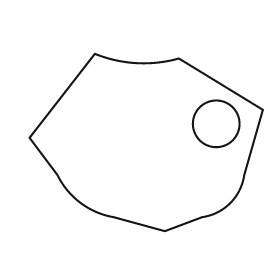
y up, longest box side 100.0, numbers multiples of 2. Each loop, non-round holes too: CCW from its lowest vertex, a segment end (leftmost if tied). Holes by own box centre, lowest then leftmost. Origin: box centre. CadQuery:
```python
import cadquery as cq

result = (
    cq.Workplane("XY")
    .moveTo(8.0, -38.0)
    .lineTo(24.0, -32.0)
    .threePointArc((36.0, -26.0), (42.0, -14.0))
    .lineTo(50.0, 14.0)
    .lineTo(14.0, 36.0)
    .threePointArc((-4.0, 34.0), (-22.0, 38.0))
    .lineTo(-50.0, 2.0)
    .lineTo(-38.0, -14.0)
    .threePointArc((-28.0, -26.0), (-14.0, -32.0))
    .close()
    .moveTo(30.0, 8.0)
    .circle(10.0)
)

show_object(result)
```